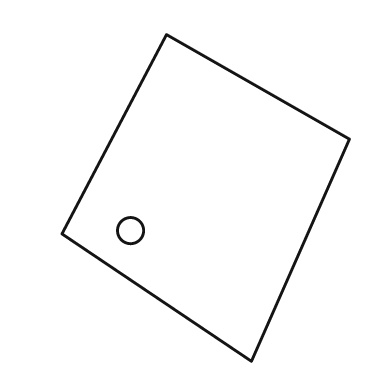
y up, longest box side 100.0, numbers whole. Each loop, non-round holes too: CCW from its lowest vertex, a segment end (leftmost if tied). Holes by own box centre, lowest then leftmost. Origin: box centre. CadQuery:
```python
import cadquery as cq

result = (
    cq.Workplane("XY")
    .moveTo(14.0, -50.0)
    .lineTo(44.0, 18.0)
    .lineTo(-12.0, 50.0)
    .lineTo(-44.0, -11.0)
    .close()
    .moveTo(-23.0, -10.0)
    .circle(4.0)
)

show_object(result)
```